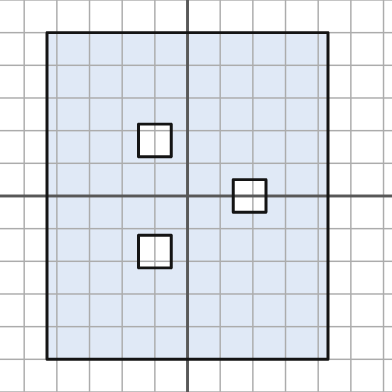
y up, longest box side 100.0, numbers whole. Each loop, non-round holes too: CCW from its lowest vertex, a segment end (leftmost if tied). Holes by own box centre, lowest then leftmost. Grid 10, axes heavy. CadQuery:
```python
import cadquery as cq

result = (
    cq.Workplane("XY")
    .moveTo(-43.0, -50.0)
    .lineTo(43.0, -50.0)
    .lineTo(43.0, 50.0)
    .lineTo(-43.0, 50.0)
    .close()
    .moveTo(-15.0, -22.0)
    .lineTo(-5.0, -22.0)
    .lineTo(-5.0, -12.0)
    .lineTo(-15.0, -12.0)
    .close()
    .moveTo(14.0, -5.0)
    .lineTo(24.0, -5.0)
    .lineTo(24.0, 5.0)
    .lineTo(14.0, 5.0)
    .close()
    .moveTo(-15.0, 12.0)
    .lineTo(-5.0, 12.0)
    .lineTo(-5.0, 22.0)
    .lineTo(-15.0, 22.0)
    .close()
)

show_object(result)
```